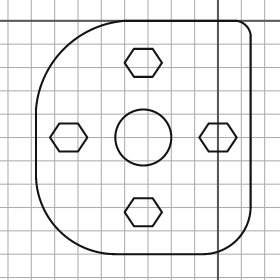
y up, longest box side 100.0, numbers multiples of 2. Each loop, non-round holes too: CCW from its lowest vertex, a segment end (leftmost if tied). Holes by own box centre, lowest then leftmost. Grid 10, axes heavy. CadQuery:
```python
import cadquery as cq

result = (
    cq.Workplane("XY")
    .moveTo(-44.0, -100.0)
    .lineTo(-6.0, -100.0)
    .threePointArc((8.0, -94.0), (14.0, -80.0))
    .lineTo(14.0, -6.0)
    .threePointArc((12.0, -2.0), (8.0, 0.0))
    .lineTo(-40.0, 0.0)
    .threePointArc((-66.0, -12.0), (-78.0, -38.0))
    .lineTo(-78.0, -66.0)
    .threePointArc((-68.0, -90.0), (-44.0, -100.0))
    .close()
    .moveTo(-36.0, -88.0)
    .lineTo(-28.0, -88.0)
    .lineTo(-24.0, -82.0)
    .lineTo(-28.0, -76.0)
    .lineTo(-36.0, -76.0)
    .lineTo(-40.0, -82.0)
    .close()
    .moveTo(-68.0, -56.0)
    .lineTo(-60.0, -56.0)
    .lineTo(-56.0, -50.0)
    .lineTo(-60.0, -44.0)
    .lineTo(-68.0, -44.0)
    .lineTo(-72.0, -50.0)
    .close()
    .moveTo(-32.0, -50.0)
    .circle(12.0)
    .moveTo(-4.0, -56.0)
    .lineTo(4.0, -56.0)
    .lineTo(8.0, -50.0)
    .lineTo(4.0, -44.0)
    .lineTo(-4.0, -44.0)
    .lineTo(-8.0, -50.0)
    .close()
    .moveTo(-36.0, -24.0)
    .lineTo(-28.0, -24.0)
    .lineTo(-24.0, -18.0)
    .lineTo(-28.0, -12.0)
    .lineTo(-36.0, -12.0)
    .lineTo(-40.0, -18.0)
    .close()
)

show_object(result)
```